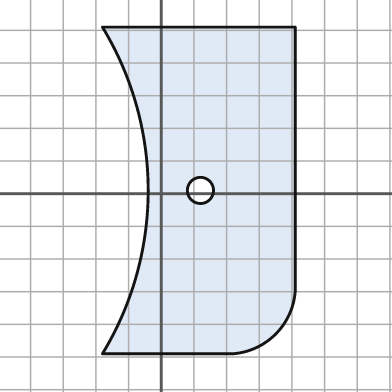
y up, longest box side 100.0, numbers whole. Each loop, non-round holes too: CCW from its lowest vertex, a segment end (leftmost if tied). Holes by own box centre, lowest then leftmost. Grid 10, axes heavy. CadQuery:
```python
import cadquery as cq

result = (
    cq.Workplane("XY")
    .moveTo(-18.0, -49.0)
    .lineTo(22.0, -49.0)
    .threePointArc((35.0, -43.0), (41.0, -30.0))
    .lineTo(41.0, 51.0)
    .lineTo(-18.0, 51.0)
    .threePointArc((-4.0, 1.0), (-18.0, -49.0))
    .close()
    .moveTo(12.0, 1.0)
    .circle(4.0)
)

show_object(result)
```